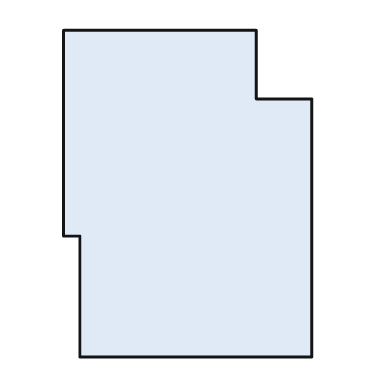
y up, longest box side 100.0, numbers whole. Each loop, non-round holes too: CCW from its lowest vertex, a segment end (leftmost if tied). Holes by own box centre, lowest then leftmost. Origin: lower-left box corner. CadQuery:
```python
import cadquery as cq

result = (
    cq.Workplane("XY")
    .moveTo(5.0, 0.0)
    .lineTo(76.0, 0.0)
    .lineTo(76.0, 79.0)
    .lineTo(59.0, 79.0)
    .lineTo(59.0, 100.0)
    .lineTo(0.0, 100.0)
    .lineTo(0.0, 37.0)
    .lineTo(5.0, 37.0)
    .close()
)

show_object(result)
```